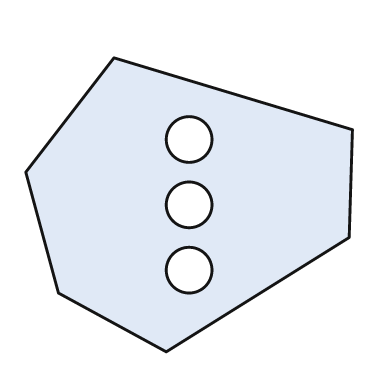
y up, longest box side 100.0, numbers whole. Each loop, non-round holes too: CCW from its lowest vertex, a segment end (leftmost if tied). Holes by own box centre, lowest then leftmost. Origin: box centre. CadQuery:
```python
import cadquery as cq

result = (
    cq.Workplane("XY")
    .moveTo(-7.0, -45.0)
    .lineTo(49.0, -10.0)
    .lineTo(50.0, 23.0)
    .lineTo(-23.0, 45.0)
    .lineTo(-50.0, 10.0)
    .lineTo(-40.0, -27.0)
    .close()
    .moveTo(0.0, -20.0)
    .circle(7.0)
    .moveTo(0.0, 0.0)
    .circle(7.0)
    .moveTo(0.0, 20.0)
    .circle(7.0)
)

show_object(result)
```